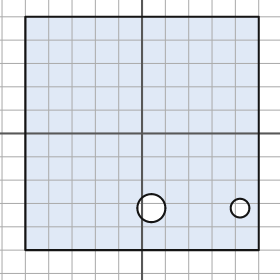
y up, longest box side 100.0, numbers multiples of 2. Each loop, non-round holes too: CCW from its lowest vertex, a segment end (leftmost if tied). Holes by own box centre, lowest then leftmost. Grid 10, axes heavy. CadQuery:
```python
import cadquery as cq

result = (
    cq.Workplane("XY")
    .moveTo(-50.0, -50.0)
    .lineTo(50.0, -50.0)
    .lineTo(50.0, 50.0)
    .lineTo(-50.0, 50.0)
    .close()
    .moveTo(4.0, -32.0)
    .circle(6.0)
    .moveTo(42.0, -32.0)
    .circle(4.0)
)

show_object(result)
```